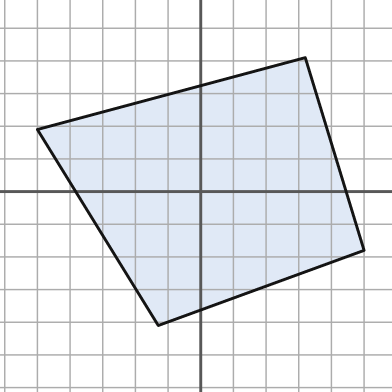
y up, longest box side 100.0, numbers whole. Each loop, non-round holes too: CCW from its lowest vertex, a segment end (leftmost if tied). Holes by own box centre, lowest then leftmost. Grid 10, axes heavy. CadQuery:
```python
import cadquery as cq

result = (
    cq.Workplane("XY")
    .moveTo(-13.0, -41.0)
    .lineTo(50.0, -18.0)
    .lineTo(32.0, 41.0)
    .lineTo(-50.0, 19.0)
    .close()
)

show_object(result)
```